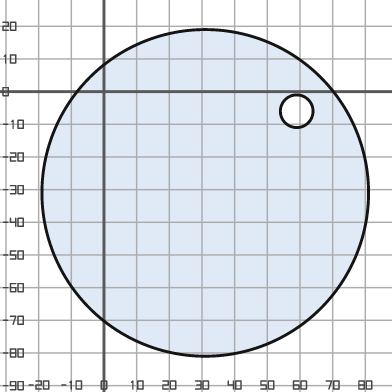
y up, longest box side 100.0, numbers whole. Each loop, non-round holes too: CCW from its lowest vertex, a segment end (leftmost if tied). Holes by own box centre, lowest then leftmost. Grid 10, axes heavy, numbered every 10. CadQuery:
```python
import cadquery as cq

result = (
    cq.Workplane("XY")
    .moveTo(31.0, -31.0)
    .circle(50.0)
    .moveTo(59.0, -6.0)
    .circle(5.0)
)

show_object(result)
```